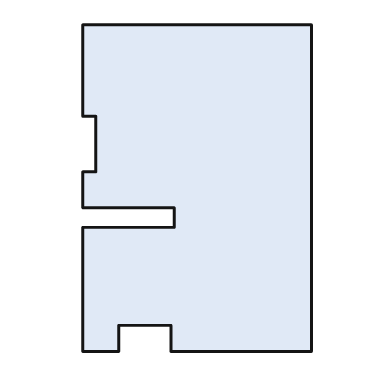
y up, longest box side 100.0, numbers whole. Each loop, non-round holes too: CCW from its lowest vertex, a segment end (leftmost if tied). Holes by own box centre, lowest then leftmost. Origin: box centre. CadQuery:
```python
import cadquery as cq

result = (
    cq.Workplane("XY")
    .moveTo(-35.0, -50.0)
    .lineTo(-24.0, -50.0)
    .lineTo(-24.0, -42.0)
    .lineTo(-8.0, -42.0)
    .lineTo(-8.0, -50.0)
    .lineTo(35.0, -50.0)
    .lineTo(35.0, 50.0)
    .lineTo(-35.0, 50.0)
    .lineTo(-35.0, 22.0)
    .lineTo(-31.0, 22.0)
    .lineTo(-31.0, 5.0)
    .lineTo(-35.0, 5.0)
    .lineTo(-35.0, -6.0)
    .lineTo(-7.0, -6.0)
    .lineTo(-7.0, -12.0)
    .lineTo(-35.0, -12.0)
    .close()
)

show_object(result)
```